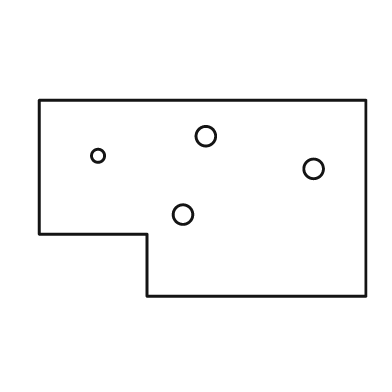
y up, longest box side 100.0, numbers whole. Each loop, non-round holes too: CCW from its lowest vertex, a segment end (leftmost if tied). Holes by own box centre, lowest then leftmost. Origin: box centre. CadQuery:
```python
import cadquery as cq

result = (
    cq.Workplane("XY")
    .moveTo(-17.0, -30.0)
    .lineTo(50.0, -30.0)
    .lineTo(50.0, 30.0)
    .lineTo(-50.0, 30.0)
    .lineTo(-50.0, -11.0)
    .lineTo(-17.0, -11.0)
    .close()
    .moveTo(-6.0, -5.0)
    .circle(3.0)
    .moveTo(34.0, 9.0)
    .circle(3.0)
    .moveTo(-32.0, 13.0)
    .circle(2.0)
    .moveTo(1.0, 19.0)
    .circle(3.0)
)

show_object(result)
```